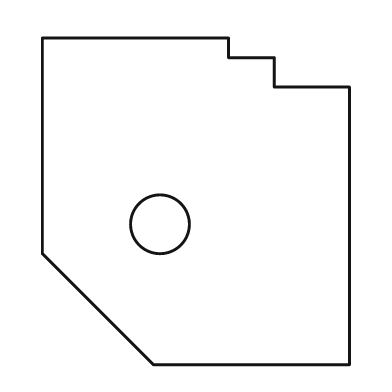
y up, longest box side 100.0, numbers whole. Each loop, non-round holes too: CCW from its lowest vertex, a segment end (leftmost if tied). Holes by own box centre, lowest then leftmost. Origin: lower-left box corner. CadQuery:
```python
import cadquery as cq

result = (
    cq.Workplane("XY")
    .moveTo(34.0, 0.0)
    .lineTo(94.0, 0.0)
    .lineTo(94.0, 85.0)
    .lineTo(71.0, 85.0)
    .lineTo(71.0, 94.0)
    .lineTo(57.0, 94.0)
    .lineTo(57.0, 100.0)
    .lineTo(0.0, 100.0)
    .lineTo(0.0, 34.0)
    .close()
    .moveTo(36.0, 43.0)
    .circle(9.0)
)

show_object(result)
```